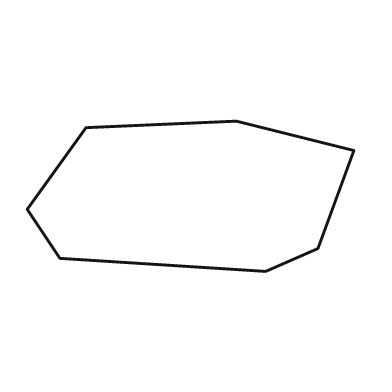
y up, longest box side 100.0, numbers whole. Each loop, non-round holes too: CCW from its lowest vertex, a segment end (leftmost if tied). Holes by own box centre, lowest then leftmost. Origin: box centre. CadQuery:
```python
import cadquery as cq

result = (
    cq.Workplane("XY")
    .moveTo(23.0, -23.0)
    .lineTo(39.0, -16.0)
    .lineTo(50.0, 14.0)
    .lineTo(14.0, 23.0)
    .lineTo(-32.0, 21.0)
    .lineTo(-50.0, -4.0)
    .lineTo(-40.0, -19.0)
    .close()
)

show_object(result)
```